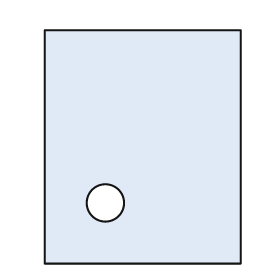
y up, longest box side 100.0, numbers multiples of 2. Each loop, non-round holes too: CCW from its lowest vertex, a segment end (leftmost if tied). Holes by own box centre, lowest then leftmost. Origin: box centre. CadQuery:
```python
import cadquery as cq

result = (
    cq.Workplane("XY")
    .moveTo(-42.0, -50.0)
    .lineTo(42.0, -50.0)
    .lineTo(42.0, 50.0)
    .lineTo(-42.0, 50.0)
    .close()
    .moveTo(-16.0, -24.0)
    .circle(8.0)
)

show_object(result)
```